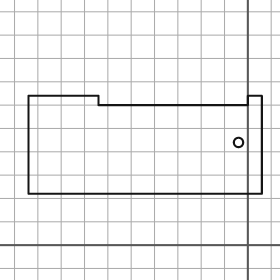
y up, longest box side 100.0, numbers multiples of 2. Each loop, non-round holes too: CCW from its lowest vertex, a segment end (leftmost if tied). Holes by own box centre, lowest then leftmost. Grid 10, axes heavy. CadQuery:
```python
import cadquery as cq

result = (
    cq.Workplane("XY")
    .moveTo(-94.0, 22.0)
    .lineTo(6.0, 22.0)
    .lineTo(6.0, 64.0)
    .lineTo(0.0, 64.0)
    .lineTo(0.0, 60.0)
    .lineTo(-64.0, 60.0)
    .lineTo(-64.0, 64.0)
    .lineTo(-94.0, 64.0)
    .close()
    .moveTo(-4.0, 44.0)
    .circle(2.0)
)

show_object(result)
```